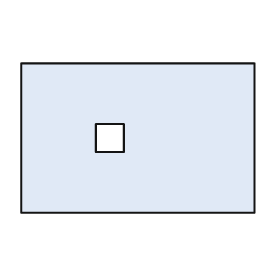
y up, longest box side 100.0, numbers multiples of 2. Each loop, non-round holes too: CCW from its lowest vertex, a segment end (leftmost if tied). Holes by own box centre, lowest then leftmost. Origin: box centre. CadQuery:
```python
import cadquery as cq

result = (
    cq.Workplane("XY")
    .moveTo(-50.0, -32.0)
    .lineTo(50.0, -32.0)
    .lineTo(50.0, 32.0)
    .lineTo(-50.0, 32.0)
    .close()
    .moveTo(-18.0, -6.0)
    .lineTo(-6.0, -6.0)
    .lineTo(-6.0, 6.0)
    .lineTo(-18.0, 6.0)
    .close()
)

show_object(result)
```